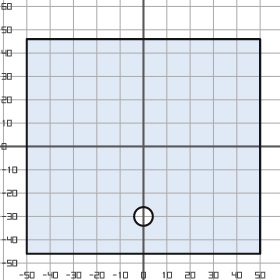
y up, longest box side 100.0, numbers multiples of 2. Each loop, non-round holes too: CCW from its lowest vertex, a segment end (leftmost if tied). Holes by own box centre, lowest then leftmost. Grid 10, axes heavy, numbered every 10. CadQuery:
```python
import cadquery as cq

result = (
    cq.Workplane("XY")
    .moveTo(-50.0, -46.0)
    .lineTo(50.0, -46.0)
    .lineTo(50.0, 46.0)
    .lineTo(-50.0, 46.0)
    .close()
    .moveTo(0.0, -30.0)
    .circle(4.0)
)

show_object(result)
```